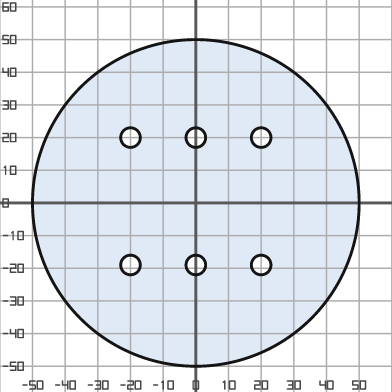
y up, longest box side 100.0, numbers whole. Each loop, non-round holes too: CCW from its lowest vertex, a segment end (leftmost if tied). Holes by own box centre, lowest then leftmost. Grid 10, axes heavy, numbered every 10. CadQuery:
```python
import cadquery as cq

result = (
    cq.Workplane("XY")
    .moveTo(0.0, 0.0)
    .circle(50.0)
    .moveTo(-20.0, -19.0)
    .circle(3.0)
    .moveTo(0.0, -19.0)
    .circle(3.0)
    .moveTo(20.0, -19.0)
    .circle(3.0)
    .moveTo(-20.0, 20.0)
    .circle(3.0)
    .moveTo(0.0, 20.0)
    .circle(3.0)
    .moveTo(20.0, 20.0)
    .circle(3.0)
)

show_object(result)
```